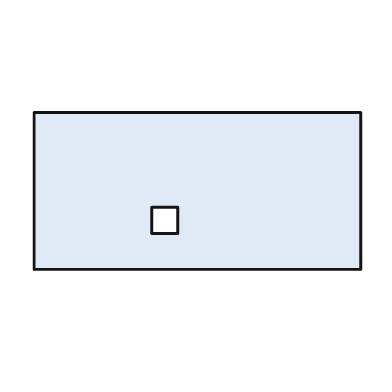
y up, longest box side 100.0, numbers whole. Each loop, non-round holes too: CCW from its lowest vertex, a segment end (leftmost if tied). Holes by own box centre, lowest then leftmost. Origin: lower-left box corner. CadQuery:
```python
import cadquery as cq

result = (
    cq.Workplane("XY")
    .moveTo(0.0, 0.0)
    .lineTo(100.0, 0.0)
    .lineTo(100.0, 48.0)
    .lineTo(0.0, 48.0)
    .close()
    .moveTo(36.0, 11.0)
    .lineTo(44.0, 11.0)
    .lineTo(44.0, 19.0)
    .lineTo(36.0, 19.0)
    .close()
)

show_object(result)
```